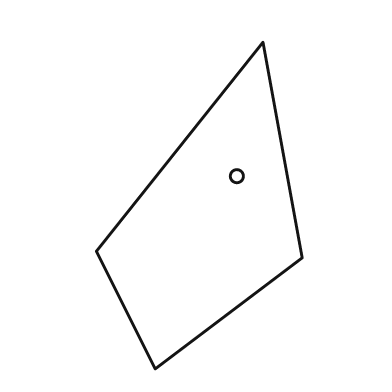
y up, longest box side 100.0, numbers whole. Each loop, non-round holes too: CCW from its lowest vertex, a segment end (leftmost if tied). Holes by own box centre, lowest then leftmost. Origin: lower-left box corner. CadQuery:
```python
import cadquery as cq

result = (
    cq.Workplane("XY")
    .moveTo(18.0, 0.0)
    .lineTo(63.0, 34.0)
    .lineTo(51.0, 100.0)
    .lineTo(0.0, 36.0)
    .close()
    .moveTo(43.0, 59.0)
    .circle(2.0)
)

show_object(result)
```